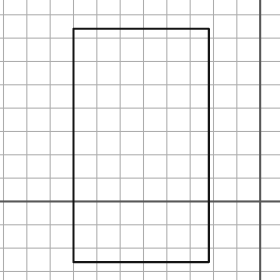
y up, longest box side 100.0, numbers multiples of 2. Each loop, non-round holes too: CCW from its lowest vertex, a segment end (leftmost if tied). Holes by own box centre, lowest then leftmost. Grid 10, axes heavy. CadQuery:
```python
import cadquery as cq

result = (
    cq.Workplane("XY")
    .moveTo(-80.0, -26.0)
    .lineTo(-22.0, -26.0)
    .lineTo(-22.0, 74.0)
    .lineTo(-80.0, 74.0)
    .close()
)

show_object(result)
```